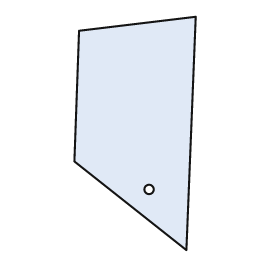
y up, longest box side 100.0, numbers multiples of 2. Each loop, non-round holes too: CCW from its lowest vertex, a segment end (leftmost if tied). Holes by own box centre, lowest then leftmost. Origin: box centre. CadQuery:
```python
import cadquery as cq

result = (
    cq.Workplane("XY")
    .moveTo(22.0, -50.0)
    .lineTo(26.0, 50.0)
    .lineTo(-24.0, 44.0)
    .lineTo(-26.0, -12.0)
    .close()
    .moveTo(6.0, -24.0)
    .circle(2.0)
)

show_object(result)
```